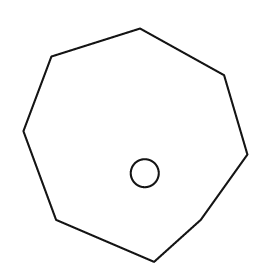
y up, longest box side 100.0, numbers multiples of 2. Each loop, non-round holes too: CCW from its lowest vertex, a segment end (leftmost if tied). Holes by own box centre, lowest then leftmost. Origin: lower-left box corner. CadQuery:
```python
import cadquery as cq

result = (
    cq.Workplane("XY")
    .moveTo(56.0, 0.0)
    .lineTo(76.0, 18.0)
    .lineTo(96.0, 46.0)
    .lineTo(86.0, 80.0)
    .lineTo(50.0, 100.0)
    .lineTo(12.0, 88.0)
    .lineTo(0.0, 56.0)
    .lineTo(14.0, 18.0)
    .close()
    .moveTo(52.0, 38.0)
    .circle(6.0)
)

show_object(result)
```